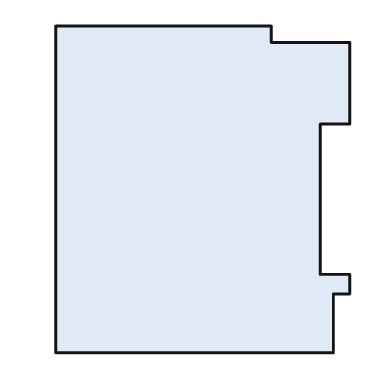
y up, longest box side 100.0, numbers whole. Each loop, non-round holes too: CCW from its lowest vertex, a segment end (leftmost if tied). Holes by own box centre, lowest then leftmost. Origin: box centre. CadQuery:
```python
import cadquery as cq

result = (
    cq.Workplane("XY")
    .moveTo(-45.0, -50.0)
    .lineTo(40.0, -50.0)
    .lineTo(40.0, -32.0)
    .lineTo(45.0, -32.0)
    .lineTo(45.0, -26.0)
    .lineTo(36.0, -26.0)
    .lineTo(36.0, 20.0)
    .lineTo(45.0, 20.0)
    .lineTo(45.0, 45.0)
    .lineTo(21.0, 45.0)
    .lineTo(21.0, 50.0)
    .lineTo(-45.0, 50.0)
    .close()
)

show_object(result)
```